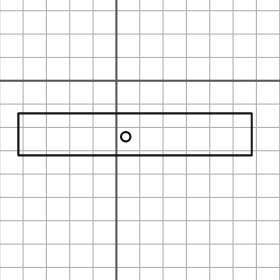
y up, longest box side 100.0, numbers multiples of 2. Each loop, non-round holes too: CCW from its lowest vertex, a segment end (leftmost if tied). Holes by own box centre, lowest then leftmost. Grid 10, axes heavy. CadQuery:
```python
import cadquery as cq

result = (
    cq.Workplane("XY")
    .moveTo(-42.0, -32.0)
    .lineTo(58.0, -32.0)
    .lineTo(58.0, -14.0)
    .lineTo(-42.0, -14.0)
    .close()
    .moveTo(4.0, -24.0)
    .circle(2.0)
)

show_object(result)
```